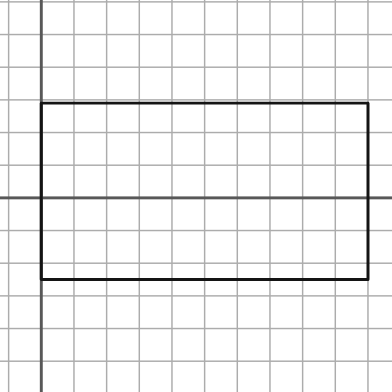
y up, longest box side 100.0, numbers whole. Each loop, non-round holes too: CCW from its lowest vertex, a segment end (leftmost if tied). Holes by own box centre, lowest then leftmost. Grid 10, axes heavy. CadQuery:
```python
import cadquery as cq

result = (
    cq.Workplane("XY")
    .moveTo(0.0, -25.0)
    .lineTo(100.0, -25.0)
    .lineTo(100.0, 29.0)
    .lineTo(0.0, 29.0)
    .close()
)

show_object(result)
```